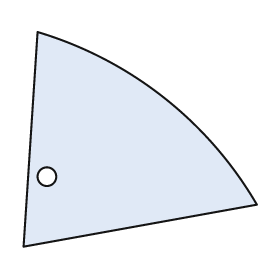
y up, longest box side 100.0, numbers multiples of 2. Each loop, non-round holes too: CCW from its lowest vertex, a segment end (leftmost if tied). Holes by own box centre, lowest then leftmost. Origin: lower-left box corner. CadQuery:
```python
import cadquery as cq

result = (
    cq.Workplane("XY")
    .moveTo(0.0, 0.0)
    .lineTo(100.0, 18.0)
    .threePointArc((60.0, 64.0), (6.0, 92.0))
    .close()
    .moveTo(10.0, 30.0)
    .circle(4.0)
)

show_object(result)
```